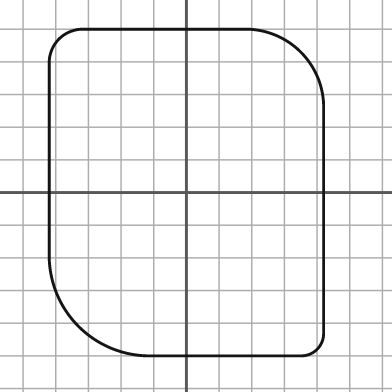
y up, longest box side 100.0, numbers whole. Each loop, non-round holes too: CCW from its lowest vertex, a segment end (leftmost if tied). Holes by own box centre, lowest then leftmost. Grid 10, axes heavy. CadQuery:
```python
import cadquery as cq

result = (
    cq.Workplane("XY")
    .moveTo(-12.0, -50.0)
    .lineTo(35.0, -50.0)
    .threePointArc((40.0, -48.0), (42.0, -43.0))
    .lineTo(42.0, 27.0)
    .threePointArc((35.0, 43.0), (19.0, 50.0))
    .lineTo(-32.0, 50.0)
    .threePointArc((-39.0, 47.0), (-42.0, 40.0))
    .lineTo(-42.0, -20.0)
    .threePointArc((-33.0, -41.0), (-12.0, -50.0))
    .close()
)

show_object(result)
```